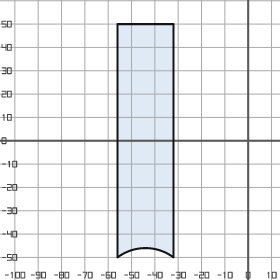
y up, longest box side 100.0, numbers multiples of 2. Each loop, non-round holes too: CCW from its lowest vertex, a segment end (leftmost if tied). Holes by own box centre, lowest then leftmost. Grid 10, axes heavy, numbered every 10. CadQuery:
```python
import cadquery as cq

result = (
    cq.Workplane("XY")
    .moveTo(-56.0, -50.0)
    .threePointArc((-44.0, -46.0), (-32.0, -50.0))
    .lineTo(-32.0, 50.0)
    .lineTo(-56.0, 50.0)
    .close()
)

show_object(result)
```